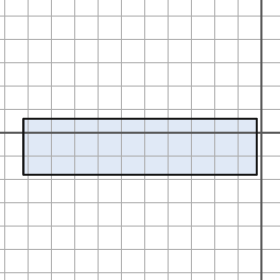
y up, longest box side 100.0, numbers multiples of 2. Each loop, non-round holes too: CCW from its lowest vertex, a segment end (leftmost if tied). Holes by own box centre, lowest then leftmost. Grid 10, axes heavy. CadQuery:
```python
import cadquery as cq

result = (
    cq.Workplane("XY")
    .moveTo(-102.0, -18.0)
    .lineTo(-2.0, -18.0)
    .lineTo(-2.0, 6.0)
    .lineTo(-102.0, 6.0)
    .close()
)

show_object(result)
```